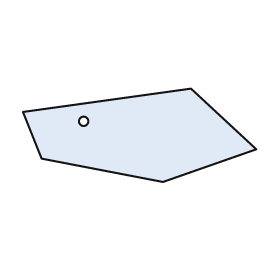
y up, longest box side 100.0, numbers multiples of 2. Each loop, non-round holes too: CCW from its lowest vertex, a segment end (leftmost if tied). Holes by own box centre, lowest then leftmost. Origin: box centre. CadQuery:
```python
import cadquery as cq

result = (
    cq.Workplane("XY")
    .moveTo(10.0, -20.0)
    .lineTo(50.0, -6.0)
    .lineTo(22.0, 20.0)
    .lineTo(-50.0, 10.0)
    .lineTo(-42.0, -10.0)
    .close()
    .moveTo(-24.0, 6.0)
    .circle(2.0)
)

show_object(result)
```